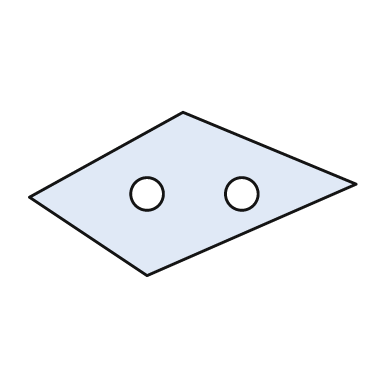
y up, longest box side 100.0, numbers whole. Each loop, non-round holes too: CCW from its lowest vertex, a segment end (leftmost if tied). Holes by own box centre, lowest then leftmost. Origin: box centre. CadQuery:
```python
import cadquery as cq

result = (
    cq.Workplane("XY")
    .moveTo(-14.0, -25.0)
    .lineTo(50.0, 3.0)
    .lineTo(-3.0, 25.0)
    .lineTo(-50.0, -1.0)
    .close()
    .moveTo(-14.0, 0.0)
    .circle(5.0)
    .moveTo(15.0, 0.0)
    .circle(5.0)
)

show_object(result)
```